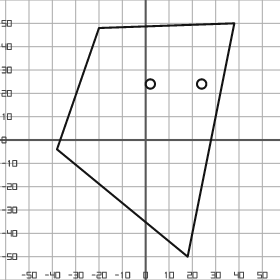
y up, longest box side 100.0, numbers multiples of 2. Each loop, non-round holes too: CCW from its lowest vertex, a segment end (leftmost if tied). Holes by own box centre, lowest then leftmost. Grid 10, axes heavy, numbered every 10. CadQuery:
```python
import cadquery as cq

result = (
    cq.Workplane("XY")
    .moveTo(18.0, -50.0)
    .lineTo(38.0, 50.0)
    .lineTo(-20.0, 48.0)
    .lineTo(-38.0, -4.0)
    .close()
    .moveTo(2.0, 24.0)
    .circle(2.0)
    .moveTo(24.0, 24.0)
    .circle(2.0)
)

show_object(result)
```